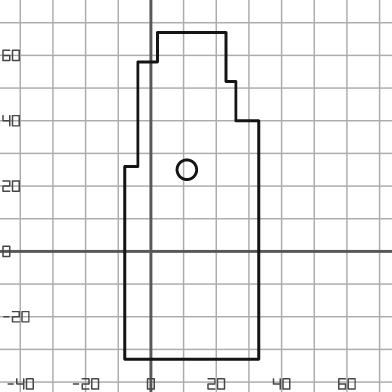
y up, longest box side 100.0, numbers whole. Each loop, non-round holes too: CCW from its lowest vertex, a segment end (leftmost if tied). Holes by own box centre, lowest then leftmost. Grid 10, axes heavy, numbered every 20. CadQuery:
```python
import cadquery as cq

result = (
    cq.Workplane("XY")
    .moveTo(-8.0, -33.0)
    .lineTo(33.0, -33.0)
    .lineTo(33.0, 40.0)
    .lineTo(26.0, 40.0)
    .lineTo(26.0, 52.0)
    .lineTo(23.0, 52.0)
    .lineTo(23.0, 67.0)
    .lineTo(2.0, 67.0)
    .lineTo(2.0, 58.0)
    .lineTo(-4.0, 58.0)
    .lineTo(-4.0, 26.0)
    .lineTo(-8.0, 26.0)
    .close()
    .moveTo(11.0, 25.0)
    .circle(3.0)
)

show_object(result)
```